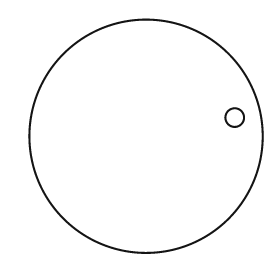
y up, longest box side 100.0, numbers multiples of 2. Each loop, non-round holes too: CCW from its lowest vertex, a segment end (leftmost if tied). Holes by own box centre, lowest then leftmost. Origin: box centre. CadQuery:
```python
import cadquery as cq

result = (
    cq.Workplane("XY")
    .moveTo(0.0, 0.0)
    .circle(50.0)
    .moveTo(38.0, 8.0)
    .circle(4.0)
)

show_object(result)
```